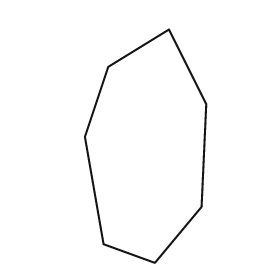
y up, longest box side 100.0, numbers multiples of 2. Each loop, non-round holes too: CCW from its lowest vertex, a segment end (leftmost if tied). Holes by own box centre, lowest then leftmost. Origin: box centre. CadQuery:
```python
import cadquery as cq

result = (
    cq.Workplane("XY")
    .moveTo(4.0, -50.0)
    .lineTo(24.0, -26.0)
    .lineTo(26.0, 18.0)
    .lineTo(10.0, 50.0)
    .lineTo(-16.0, 34.0)
    .lineTo(-26.0, 4.0)
    .lineTo(-18.0, -42.0)
    .close()
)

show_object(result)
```